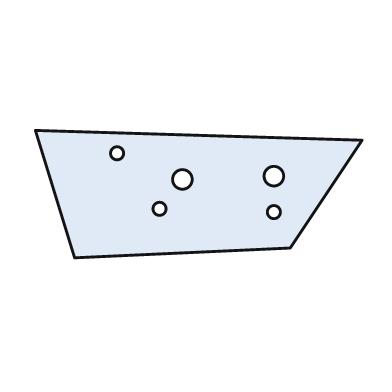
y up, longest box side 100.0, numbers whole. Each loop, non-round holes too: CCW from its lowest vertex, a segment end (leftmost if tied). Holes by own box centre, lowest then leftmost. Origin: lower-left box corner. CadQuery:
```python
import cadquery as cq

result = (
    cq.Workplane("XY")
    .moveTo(12.0, 0.0)
    .lineTo(78.0, 3.0)
    .lineTo(100.0, 36.0)
    .lineTo(0.0, 39.0)
    .close()
    .moveTo(73.0, 14.0)
    .circle(2.0)
    .moveTo(38.0, 15.0)
    .circle(2.0)
    .moveTo(45.0, 24.0)
    .circle(3.0)
    .moveTo(73.0, 25.0)
    .circle(3.0)
    .moveTo(25.0, 32.0)
    .circle(2.0)
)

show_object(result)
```